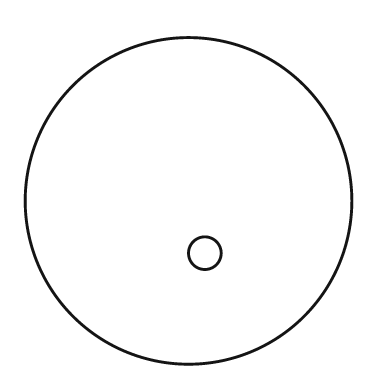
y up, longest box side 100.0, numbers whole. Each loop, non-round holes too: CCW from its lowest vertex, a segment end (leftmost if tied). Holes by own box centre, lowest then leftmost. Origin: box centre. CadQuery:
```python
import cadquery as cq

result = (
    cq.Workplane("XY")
    .moveTo(0.0, 0.0)
    .circle(50.0)
    .moveTo(5.0, -16.0)
    .circle(5.0)
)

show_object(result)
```